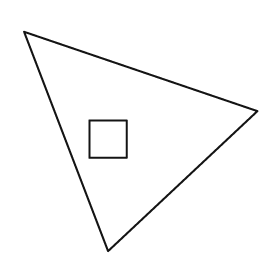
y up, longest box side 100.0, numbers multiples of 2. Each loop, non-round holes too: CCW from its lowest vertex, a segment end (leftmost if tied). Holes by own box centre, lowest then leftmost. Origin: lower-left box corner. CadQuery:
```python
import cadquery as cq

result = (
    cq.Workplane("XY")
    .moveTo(36.0, 0.0)
    .lineTo(100.0, 60.0)
    .lineTo(0.0, 94.0)
    .close()
    .moveTo(28.0, 40.0)
    .lineTo(44.0, 40.0)
    .lineTo(44.0, 56.0)
    .lineTo(28.0, 56.0)
    .close()
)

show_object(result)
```